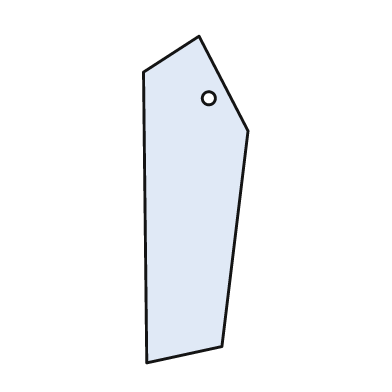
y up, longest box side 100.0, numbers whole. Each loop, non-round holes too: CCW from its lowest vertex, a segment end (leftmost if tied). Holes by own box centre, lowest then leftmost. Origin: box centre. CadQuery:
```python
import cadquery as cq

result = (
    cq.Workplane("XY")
    .moveTo(-15.0, -50.0)
    .lineTo(8.0, -45.0)
    .lineTo(16.0, 21.0)
    .lineTo(1.0, 50.0)
    .lineTo(-16.0, 39.0)
    .close()
    .moveTo(4.0, 31.0)
    .circle(2.0)
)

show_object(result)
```